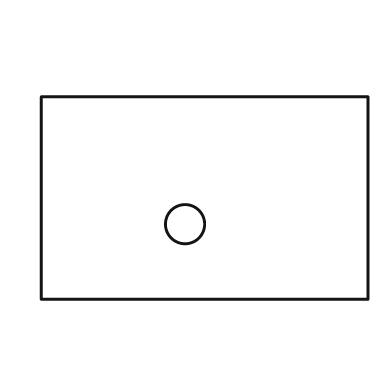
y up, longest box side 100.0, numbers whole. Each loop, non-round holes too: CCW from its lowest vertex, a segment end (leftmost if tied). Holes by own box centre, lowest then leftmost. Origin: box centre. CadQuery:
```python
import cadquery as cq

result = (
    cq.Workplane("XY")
    .moveTo(-50.0, -31.0)
    .lineTo(50.0, -31.0)
    .lineTo(50.0, 31.0)
    .lineTo(-50.0, 31.0)
    .close()
    .moveTo(-6.0, -8.0)
    .circle(6.0)
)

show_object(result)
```